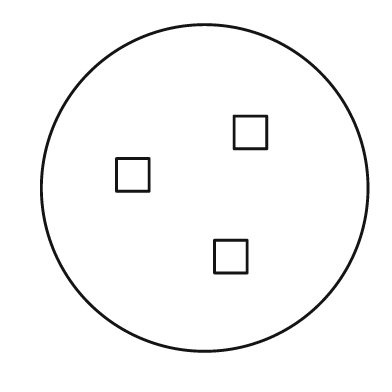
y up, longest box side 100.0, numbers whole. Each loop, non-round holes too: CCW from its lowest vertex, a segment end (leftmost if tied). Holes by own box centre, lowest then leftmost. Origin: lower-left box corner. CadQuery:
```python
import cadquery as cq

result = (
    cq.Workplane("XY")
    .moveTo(50.0, 50.0)
    .circle(50.0)
    .moveTo(53.0, 24.0)
    .lineTo(63.0, 24.0)
    .lineTo(63.0, 34.0)
    .lineTo(53.0, 34.0)
    .close()
    .moveTo(23.0, 49.0)
    .lineTo(33.0, 49.0)
    .lineTo(33.0, 59.0)
    .lineTo(23.0, 59.0)
    .close()
    .moveTo(59.0, 62.0)
    .lineTo(69.0, 62.0)
    .lineTo(69.0, 72.0)
    .lineTo(59.0, 72.0)
    .close()
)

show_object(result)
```